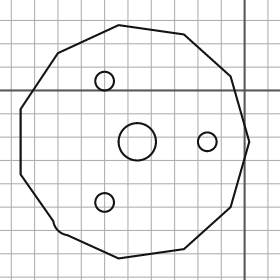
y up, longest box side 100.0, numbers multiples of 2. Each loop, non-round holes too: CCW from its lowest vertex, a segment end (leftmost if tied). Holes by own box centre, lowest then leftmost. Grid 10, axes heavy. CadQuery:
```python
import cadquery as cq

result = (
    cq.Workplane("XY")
    .moveTo(-54.0, -72.0)
    .lineTo(-26.0, -68.0)
    .lineTo(-6.0, -50.0)
    .lineTo(2.0, -22.0)
    .lineTo(-6.0, 6.0)
    .lineTo(-26.0, 24.0)
    .lineTo(-54.0, 28.0)
    .lineTo(-80.0, 16.0)
    .lineTo(-96.0, -8.0)
    .lineTo(-96.0, -36.0)
    .lineTo(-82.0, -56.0)
    .threePointArc((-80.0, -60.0), (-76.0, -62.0))
    .close()
    .moveTo(-60.0, -48.0)
    .circle(4.0)
    .moveTo(-46.0, -22.0)
    .circle(8.0)
    .moveTo(-16.0, -22.0)
    .circle(4.0)
    .moveTo(-60.0, 4.0)
    .circle(4.0)
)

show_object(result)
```